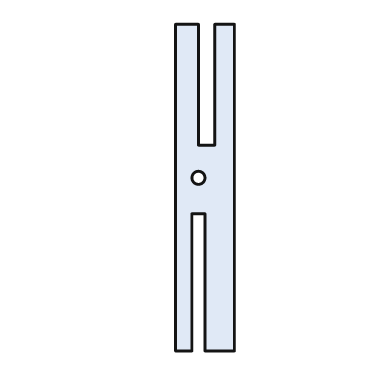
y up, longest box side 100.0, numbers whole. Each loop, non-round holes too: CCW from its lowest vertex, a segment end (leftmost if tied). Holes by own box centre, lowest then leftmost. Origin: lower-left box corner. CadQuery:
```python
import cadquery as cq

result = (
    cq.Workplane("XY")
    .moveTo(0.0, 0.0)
    .lineTo(5.0, 0.0)
    .lineTo(5.0, 42.0)
    .lineTo(9.0, 42.0)
    .lineTo(9.0, 0.0)
    .lineTo(18.0, 0.0)
    .lineTo(18.0, 100.0)
    .lineTo(12.0, 100.0)
    .lineTo(12.0, 63.0)
    .lineTo(7.0, 63.0)
    .lineTo(7.0, 100.0)
    .lineTo(0.0, 100.0)
    .close()
    .moveTo(7.0, 53.0)
    .circle(2.0)
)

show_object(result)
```